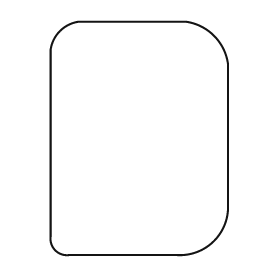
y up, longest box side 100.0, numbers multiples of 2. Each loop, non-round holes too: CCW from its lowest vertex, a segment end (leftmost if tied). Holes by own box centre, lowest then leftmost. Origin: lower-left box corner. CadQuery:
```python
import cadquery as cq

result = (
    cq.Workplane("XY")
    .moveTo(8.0, 0.0)
    .lineTo(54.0, 0.0)
    .threePointArc((70.0, 6.0), (76.0, 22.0))
    .lineTo(76.0, 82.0)
    .threePointArc((70.0, 94.0), (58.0, 100.0))
    .lineTo(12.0, 100.0)
    .threePointArc((4.0, 96.0), (0.0, 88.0))
    .lineTo(0.0, 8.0)
    .threePointArc((2.0, 2.0), (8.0, 0.0))
    .close()
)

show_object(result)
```